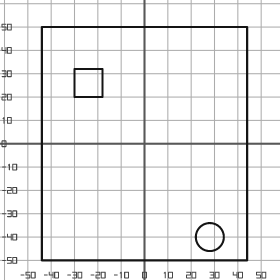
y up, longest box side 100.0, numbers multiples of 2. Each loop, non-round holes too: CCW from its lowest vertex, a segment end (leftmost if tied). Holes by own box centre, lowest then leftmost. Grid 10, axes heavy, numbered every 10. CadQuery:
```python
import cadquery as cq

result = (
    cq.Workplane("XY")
    .moveTo(-44.0, -50.0)
    .lineTo(44.0, -50.0)
    .lineTo(44.0, 50.0)
    .lineTo(-44.0, 50.0)
    .close()
    .moveTo(28.0, -40.0)
    .circle(6.0)
    .moveTo(-30.0, 20.0)
    .lineTo(-18.0, 20.0)
    .lineTo(-18.0, 32.0)
    .lineTo(-30.0, 32.0)
    .close()
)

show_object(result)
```